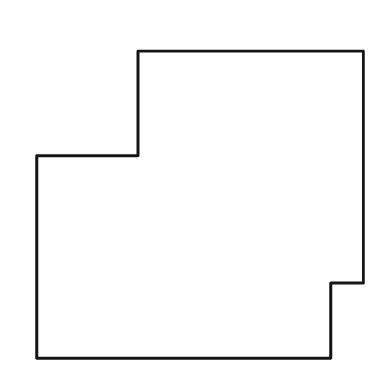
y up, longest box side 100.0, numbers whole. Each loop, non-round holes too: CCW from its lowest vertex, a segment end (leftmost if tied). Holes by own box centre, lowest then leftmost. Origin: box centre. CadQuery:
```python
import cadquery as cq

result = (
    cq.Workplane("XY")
    .moveTo(-50.0, -47.0)
    .lineTo(40.0, -47.0)
    .lineTo(40.0, -24.0)
    .lineTo(50.0, -24.0)
    .lineTo(50.0, 47.0)
    .lineTo(-19.0, 47.0)
    .lineTo(-19.0, 15.0)
    .lineTo(-50.0, 15.0)
    .close()
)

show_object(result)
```